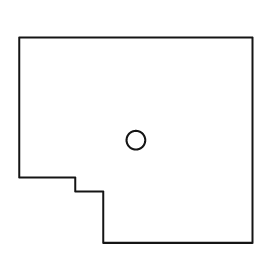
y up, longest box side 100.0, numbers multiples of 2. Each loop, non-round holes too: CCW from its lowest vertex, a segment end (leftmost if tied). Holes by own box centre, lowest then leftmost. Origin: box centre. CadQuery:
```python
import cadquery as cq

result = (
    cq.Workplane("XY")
    .moveTo(-14.0, -44.0)
    .lineTo(50.0, -44.0)
    .lineTo(50.0, 44.0)
    .lineTo(-50.0, 44.0)
    .lineTo(-50.0, -16.0)
    .lineTo(-26.0, -16.0)
    .lineTo(-26.0, -22.0)
    .lineTo(-14.0, -22.0)
    .close()
    .moveTo(0.0, 0.0)
    .circle(4.0)
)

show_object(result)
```